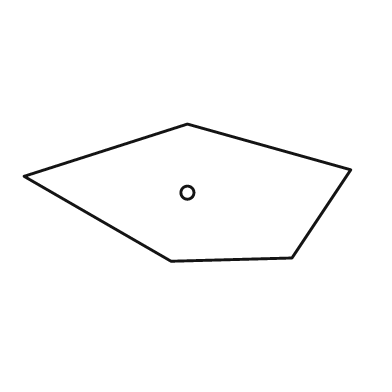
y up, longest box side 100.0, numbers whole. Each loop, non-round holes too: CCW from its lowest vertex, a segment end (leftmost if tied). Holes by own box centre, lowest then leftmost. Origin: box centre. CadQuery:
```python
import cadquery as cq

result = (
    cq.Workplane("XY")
    .moveTo(-5.0, -21.0)
    .lineTo(32.0, -20.0)
    .lineTo(50.0, 7.0)
    .lineTo(0.0, 21.0)
    .lineTo(-50.0, 5.0)
    .close()
    .moveTo(0.0, 0.0)
    .circle(2.0)
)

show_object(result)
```